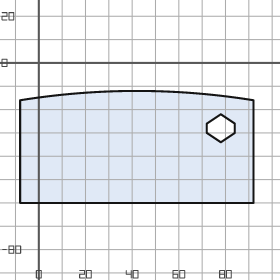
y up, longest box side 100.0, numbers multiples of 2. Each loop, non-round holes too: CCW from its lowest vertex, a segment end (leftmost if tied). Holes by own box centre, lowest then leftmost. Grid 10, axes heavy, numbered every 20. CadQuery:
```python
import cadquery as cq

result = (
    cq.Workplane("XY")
    .moveTo(-8.0, -60.0)
    .lineTo(92.0, -60.0)
    .lineTo(92.0, -16.0)
    .threePointArc((42.0, -12.0), (-8.0, -16.0))
    .close()
    .moveTo(78.0, -34.0)
    .lineTo(84.0, -30.0)
    .lineTo(84.0, -26.0)
    .lineTo(78.0, -22.0)
    .lineTo(72.0, -26.0)
    .lineTo(72.0, -30.0)
    .close()
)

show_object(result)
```